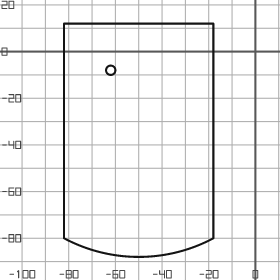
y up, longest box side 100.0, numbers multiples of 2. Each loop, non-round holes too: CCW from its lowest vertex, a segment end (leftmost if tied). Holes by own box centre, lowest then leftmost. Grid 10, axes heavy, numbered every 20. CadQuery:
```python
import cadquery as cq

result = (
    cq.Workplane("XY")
    .moveTo(-82.0, -80.0)
    .threePointArc((-50.0, -88.0), (-18.0, -80.0))
    .lineTo(-18.0, 12.0)
    .lineTo(-82.0, 12.0)
    .close()
    .moveTo(-62.0, -8.0)
    .circle(2.0)
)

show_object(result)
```